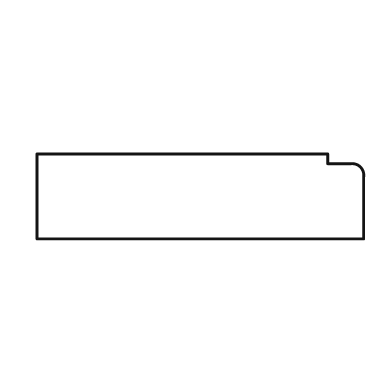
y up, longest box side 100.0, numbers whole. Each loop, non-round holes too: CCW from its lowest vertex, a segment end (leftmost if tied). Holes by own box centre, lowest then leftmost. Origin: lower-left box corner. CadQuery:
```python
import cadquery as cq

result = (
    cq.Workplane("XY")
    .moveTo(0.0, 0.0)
    .lineTo(100.0, 0.0)
    .lineTo(100.0, 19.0)
    .threePointArc((99.0, 22.0), (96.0, 23.0))
    .lineTo(89.0, 23.0)
    .lineTo(89.0, 26.0)
    .lineTo(0.0, 26.0)
    .close()
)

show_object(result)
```